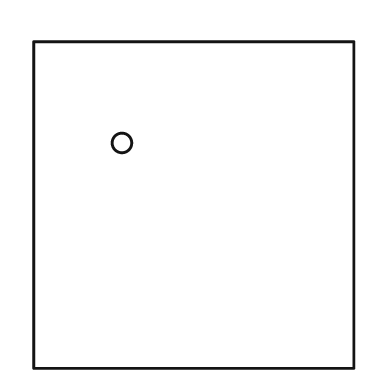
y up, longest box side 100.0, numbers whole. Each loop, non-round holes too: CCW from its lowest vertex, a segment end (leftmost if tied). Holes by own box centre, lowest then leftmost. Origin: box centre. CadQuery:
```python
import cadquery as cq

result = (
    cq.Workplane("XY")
    .moveTo(-49.0, -50.0)
    .lineTo(49.0, -50.0)
    .lineTo(49.0, 50.0)
    .lineTo(-49.0, 50.0)
    .close()
    .moveTo(-22.0, 19.0)
    .circle(3.0)
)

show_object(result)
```